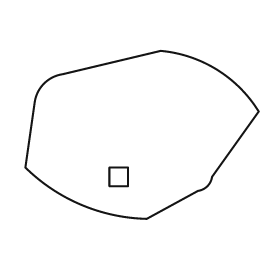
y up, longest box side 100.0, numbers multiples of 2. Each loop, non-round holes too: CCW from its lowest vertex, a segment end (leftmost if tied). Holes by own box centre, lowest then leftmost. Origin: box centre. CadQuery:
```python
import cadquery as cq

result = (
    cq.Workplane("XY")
    .moveTo(2.0, -36.0)
    .lineTo(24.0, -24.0)
    .threePointArc((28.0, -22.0), (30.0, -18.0))
    .lineTo(50.0, 10.0)
    .threePointArc((32.0, 28.0), (8.0, 36.0))
    .lineTo(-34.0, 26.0)
    .threePointArc((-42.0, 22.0), (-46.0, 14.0))
    .lineTo(-50.0, -14.0)
    .threePointArc((-26.0, -30.0), (2.0, -36.0))
    .close()
    .moveTo(-14.0, -22.0)
    .lineTo(-6.0, -22.0)
    .lineTo(-6.0, -14.0)
    .lineTo(-14.0, -14.0)
    .close()
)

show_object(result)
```